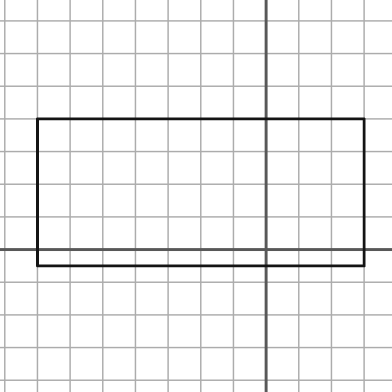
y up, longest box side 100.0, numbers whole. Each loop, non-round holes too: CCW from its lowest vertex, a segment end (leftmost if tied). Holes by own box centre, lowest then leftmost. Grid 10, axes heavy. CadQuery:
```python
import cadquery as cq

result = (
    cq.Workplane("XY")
    .moveTo(-70.0, -5.0)
    .lineTo(30.0, -5.0)
    .lineTo(30.0, 40.0)
    .lineTo(-70.0, 40.0)
    .close()
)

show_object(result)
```